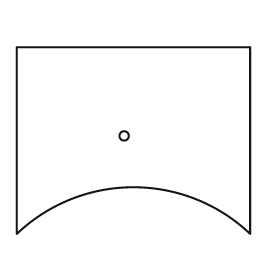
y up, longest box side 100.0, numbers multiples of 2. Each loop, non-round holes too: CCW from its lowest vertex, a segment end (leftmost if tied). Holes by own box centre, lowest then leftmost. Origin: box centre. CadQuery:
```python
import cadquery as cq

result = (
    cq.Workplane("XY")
    .moveTo(-50.0, -40.0)
    .threePointArc((0.0, -20.0), (50.0, -40.0))
    .lineTo(50.0, 40.0)
    .lineTo(-50.0, 40.0)
    .close()
    .moveTo(-4.0, 2.0)
    .circle(2.0)
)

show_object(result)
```